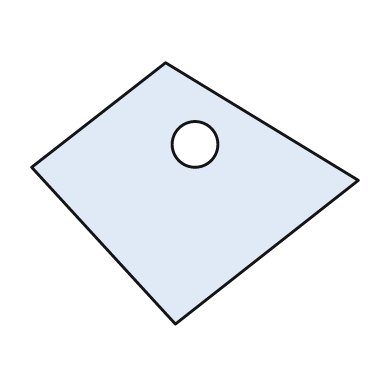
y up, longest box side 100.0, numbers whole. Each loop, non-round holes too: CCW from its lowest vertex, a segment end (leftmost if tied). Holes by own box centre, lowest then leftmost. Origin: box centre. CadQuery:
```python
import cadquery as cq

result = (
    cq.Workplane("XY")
    .moveTo(-6.0, -40.0)
    .lineTo(50.0, 4.0)
    .lineTo(-9.0, 40.0)
    .lineTo(-50.0, 8.0)
    .close()
    .moveTo(0.0, 15.0)
    .circle(7.0)
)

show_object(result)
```